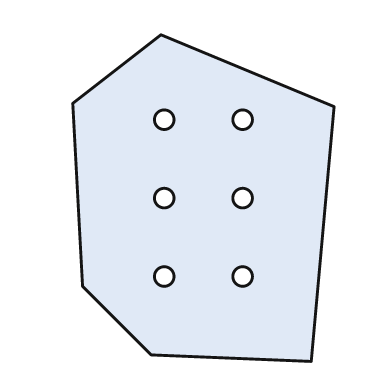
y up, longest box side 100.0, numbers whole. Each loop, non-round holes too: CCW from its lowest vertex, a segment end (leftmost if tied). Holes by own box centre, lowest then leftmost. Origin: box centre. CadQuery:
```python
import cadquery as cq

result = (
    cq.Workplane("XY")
    .moveTo(33.0, -50.0)
    .lineTo(40.0, 28.0)
    .lineTo(-13.0, 50.0)
    .lineTo(-40.0, 29.0)
    .lineTo(-37.0, -27.0)
    .lineTo(-16.0, -48.0)
    .close()
    .moveTo(-12.0, -24.0)
    .circle(3.0)
    .moveTo(12.0, -24.0)
    .circle(3.0)
    .moveTo(-12.0, 0.0)
    .circle(3.0)
    .moveTo(12.0, 0.0)
    .circle(3.0)
    .moveTo(-12.0, 24.0)
    .circle(3.0)
    .moveTo(12.0, 24.0)
    .circle(3.0)
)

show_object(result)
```